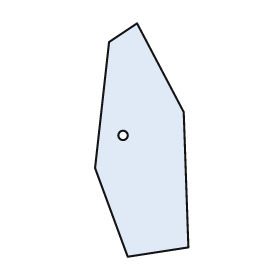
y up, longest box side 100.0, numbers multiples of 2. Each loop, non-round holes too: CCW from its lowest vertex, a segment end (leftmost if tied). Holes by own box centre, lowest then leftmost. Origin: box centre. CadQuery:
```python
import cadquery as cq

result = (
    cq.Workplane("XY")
    .moveTo(-6.0, -50.0)
    .lineTo(20.0, -46.0)
    .lineTo(18.0, 12.0)
    .lineTo(-2.0, 50.0)
    .lineTo(-14.0, 42.0)
    .lineTo(-20.0, -12.0)
    .close()
    .moveTo(-8.0, 2.0)
    .circle(2.0)
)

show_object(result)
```